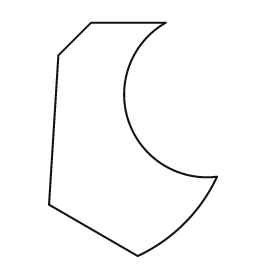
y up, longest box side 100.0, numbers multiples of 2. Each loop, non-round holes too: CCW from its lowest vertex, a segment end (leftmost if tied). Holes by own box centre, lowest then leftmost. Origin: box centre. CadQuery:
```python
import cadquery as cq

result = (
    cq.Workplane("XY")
    .moveTo(2.0, -50.0)
    .threePointArc((22.0, -36.0), (36.0, -16.0))
    .threePointArc((-2.0, 8.0), (14.0, 50.0))
    .lineTo(-18.0, 50.0)
    .lineTo(-32.0, 36.0)
    .lineTo(-36.0, -28.0)
    .close()
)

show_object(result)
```